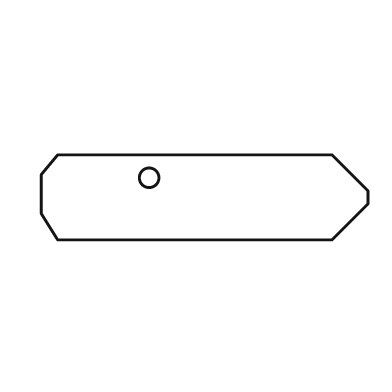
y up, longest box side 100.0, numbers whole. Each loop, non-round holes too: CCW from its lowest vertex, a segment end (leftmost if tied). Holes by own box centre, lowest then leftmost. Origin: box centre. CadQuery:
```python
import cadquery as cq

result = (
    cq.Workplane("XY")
    .moveTo(-45.0, -13.0)
    .lineTo(39.0, -13.0)
    .lineTo(50.0, -2.0)
    .lineTo(50.0, 2.0)
    .lineTo(39.0, 13.0)
    .lineTo(-45.0, 13.0)
    .lineTo(-50.0, 7.0)
    .lineTo(-50.0, -5.0)
    .close()
    .moveTo(-17.0, 6.0)
    .circle(3.0)
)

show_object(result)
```